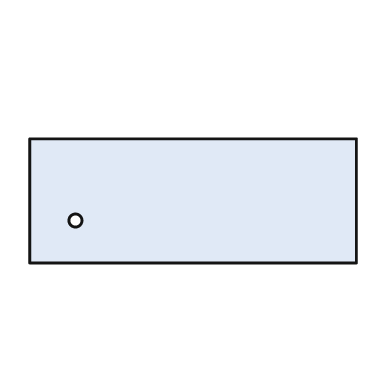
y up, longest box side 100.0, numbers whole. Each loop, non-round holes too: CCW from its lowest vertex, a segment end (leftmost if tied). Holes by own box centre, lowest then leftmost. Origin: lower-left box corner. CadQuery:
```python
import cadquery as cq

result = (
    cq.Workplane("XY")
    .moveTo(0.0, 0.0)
    .lineTo(100.0, 0.0)
    .lineTo(100.0, 38.0)
    .lineTo(0.0, 38.0)
    .close()
    .moveTo(14.0, 13.0)
    .circle(2.0)
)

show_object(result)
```